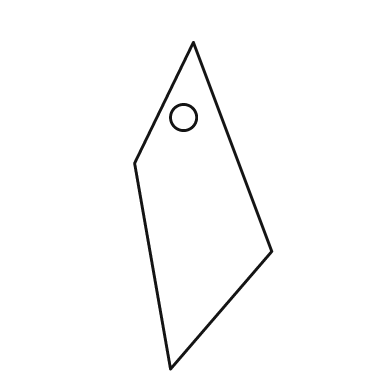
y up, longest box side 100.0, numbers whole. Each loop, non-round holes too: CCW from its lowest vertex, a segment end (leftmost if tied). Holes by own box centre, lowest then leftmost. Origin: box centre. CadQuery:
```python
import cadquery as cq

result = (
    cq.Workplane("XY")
    .moveTo(-10.0, -50.0)
    .lineTo(21.0, -14.0)
    .lineTo(-3.0, 50.0)
    .lineTo(-21.0, 13.0)
    .close()
    .moveTo(-6.0, 27.0)
    .circle(4.0)
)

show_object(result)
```